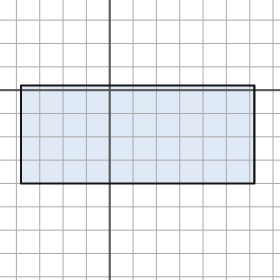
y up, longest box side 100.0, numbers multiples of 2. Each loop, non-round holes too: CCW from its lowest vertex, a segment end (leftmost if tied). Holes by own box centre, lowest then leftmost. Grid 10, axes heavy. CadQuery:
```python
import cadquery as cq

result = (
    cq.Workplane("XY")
    .moveTo(-38.0, -40.0)
    .lineTo(62.0, -40.0)
    .lineTo(62.0, 2.0)
    .lineTo(-38.0, 2.0)
    .close()
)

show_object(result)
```